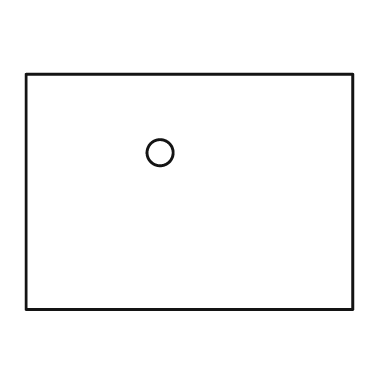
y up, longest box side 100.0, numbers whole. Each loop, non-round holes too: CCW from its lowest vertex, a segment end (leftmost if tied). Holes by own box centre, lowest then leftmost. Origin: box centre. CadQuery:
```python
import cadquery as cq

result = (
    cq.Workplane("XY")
    .moveTo(-50.0, -36.0)
    .lineTo(50.0, -36.0)
    .lineTo(50.0, 36.0)
    .lineTo(-50.0, 36.0)
    .close()
    .moveTo(-9.0, 12.0)
    .circle(4.0)
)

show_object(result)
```